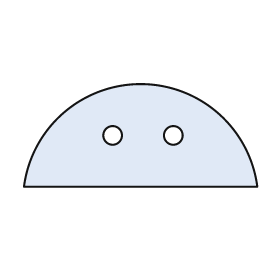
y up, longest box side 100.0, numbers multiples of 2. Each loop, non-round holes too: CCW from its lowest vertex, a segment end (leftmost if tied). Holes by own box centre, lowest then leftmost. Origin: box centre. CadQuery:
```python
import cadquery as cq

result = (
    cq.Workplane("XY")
    .moveTo(-50.0, -22.0)
    .lineTo(50.0, -22.0)
    .threePointArc((0.0, 22.0), (-50.0, -22.0))
    .close()
    .moveTo(-12.0, 0.0)
    .circle(4.0)
    .moveTo(14.0, 0.0)
    .circle(4.0)
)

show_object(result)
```